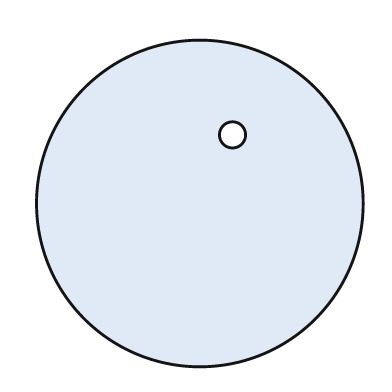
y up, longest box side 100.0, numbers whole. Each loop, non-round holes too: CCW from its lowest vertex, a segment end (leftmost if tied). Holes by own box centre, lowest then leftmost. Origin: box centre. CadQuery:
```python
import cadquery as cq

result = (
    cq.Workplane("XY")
    .moveTo(0.0, 0.0)
    .circle(50.0)
    .moveTo(10.0, 21.0)
    .circle(4.0)
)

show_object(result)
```